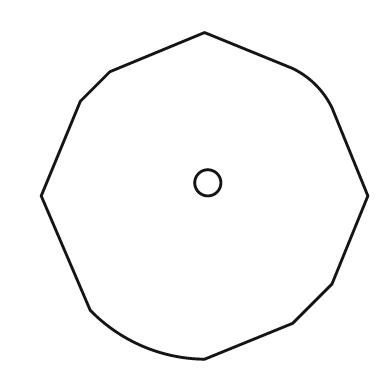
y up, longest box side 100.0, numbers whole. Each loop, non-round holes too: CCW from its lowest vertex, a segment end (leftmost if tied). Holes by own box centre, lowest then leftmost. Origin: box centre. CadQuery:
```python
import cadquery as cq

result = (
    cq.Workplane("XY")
    .moveTo(0.0, -50.0)
    .lineTo(27.0, -39.0)
    .lineTo(39.0, -27.0)
    .lineTo(50.0, 0.0)
    .lineTo(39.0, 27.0)
    .threePointArc((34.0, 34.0), (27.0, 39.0))
    .lineTo(0.0, 50.0)
    .lineTo(-29.0, 38.0)
    .lineTo(-38.0, 29.0)
    .lineTo(-50.0, 0.0)
    .lineTo(-35.0, -35.0)
    .threePointArc((-19.0, -46.0), (0.0, -50.0))
    .close()
    .moveTo(1.0, 4.0)
    .circle(4.0)
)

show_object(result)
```